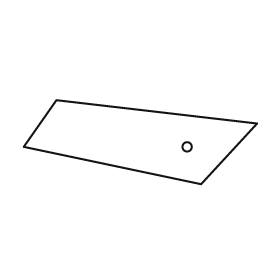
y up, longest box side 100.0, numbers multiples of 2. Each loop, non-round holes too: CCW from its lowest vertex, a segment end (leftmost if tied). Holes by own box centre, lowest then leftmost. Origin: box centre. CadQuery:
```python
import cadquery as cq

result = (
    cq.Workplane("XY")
    .moveTo(26.0, -18.0)
    .lineTo(50.0, 8.0)
    .lineTo(-36.0, 18.0)
    .lineTo(-50.0, -2.0)
    .close()
    .moveTo(20.0, -2.0)
    .circle(2.0)
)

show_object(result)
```